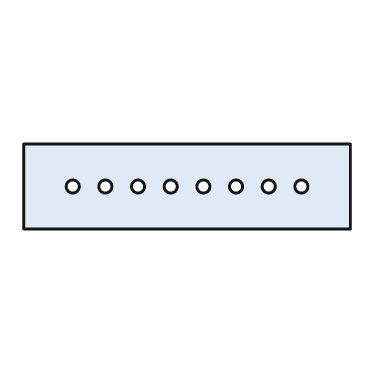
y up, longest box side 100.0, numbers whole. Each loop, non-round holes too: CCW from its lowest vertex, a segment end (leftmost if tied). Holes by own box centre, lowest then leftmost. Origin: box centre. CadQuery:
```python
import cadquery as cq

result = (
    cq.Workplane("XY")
    .moveTo(-50.0, -13.0)
    .lineTo(50.0, -13.0)
    .lineTo(50.0, 13.0)
    .lineTo(-50.0, 13.0)
    .close()
    .moveTo(-35.0, 0.0)
    .circle(2.0)
    .moveTo(-25.0, 0.0)
    .circle(2.0)
    .moveTo(-15.0, 0.0)
    .circle(2.0)
    .moveTo(-5.0, 0.0)
    .circle(2.0)
    .moveTo(5.0, 0.0)
    .circle(2.0)
    .moveTo(15.0, 0.0)
    .circle(2.0)
    .moveTo(25.0, 0.0)
    .circle(2.0)
    .moveTo(35.0, 0.0)
    .circle(2.0)
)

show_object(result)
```